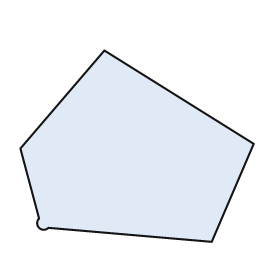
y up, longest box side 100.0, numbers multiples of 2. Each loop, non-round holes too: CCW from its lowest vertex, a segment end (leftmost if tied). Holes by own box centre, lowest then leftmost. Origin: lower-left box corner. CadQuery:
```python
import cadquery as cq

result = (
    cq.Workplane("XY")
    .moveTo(82.0, 0.0)
    .lineTo(100.0, 42.0)
    .lineTo(36.0, 82.0)
    .lineTo(0.0, 40.0)
    .lineTo(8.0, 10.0)
    .threePointArc((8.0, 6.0), (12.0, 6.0))
    .close()
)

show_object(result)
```